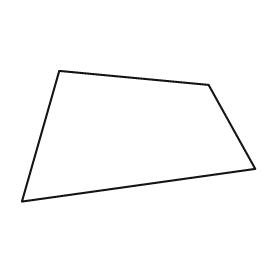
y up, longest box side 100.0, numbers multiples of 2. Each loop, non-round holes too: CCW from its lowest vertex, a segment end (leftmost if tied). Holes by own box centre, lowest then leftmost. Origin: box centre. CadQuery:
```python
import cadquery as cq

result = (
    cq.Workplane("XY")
    .moveTo(-50.0, -28.0)
    .lineTo(50.0, -14.0)
    .lineTo(30.0, 22.0)
    .lineTo(-34.0, 28.0)
    .close()
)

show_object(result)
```